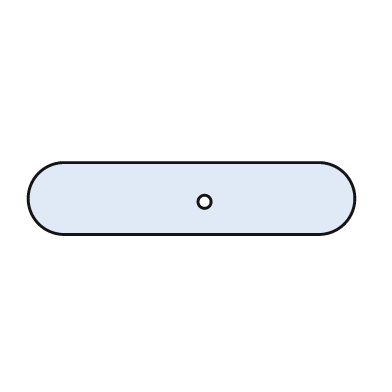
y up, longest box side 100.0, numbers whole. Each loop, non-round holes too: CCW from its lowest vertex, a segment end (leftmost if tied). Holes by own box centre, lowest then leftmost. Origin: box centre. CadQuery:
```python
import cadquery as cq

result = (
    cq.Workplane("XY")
    .moveTo(-39.0, -11.0)
    .lineTo(39.0, -11.0)
    .threePointArc((50.0, 0.0), (39.0, 11.0))
    .lineTo(-39.0, 11.0)
    .threePointArc((-50.0, 0.0), (-39.0, -11.0))
    .close()
    .moveTo(4.0, -1.0)
    .circle(2.0)
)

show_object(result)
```